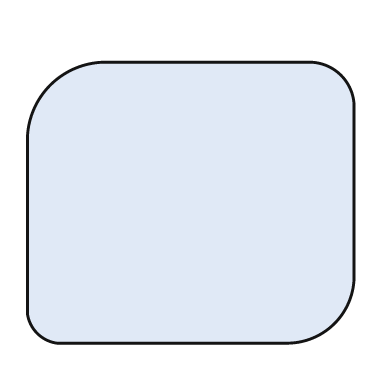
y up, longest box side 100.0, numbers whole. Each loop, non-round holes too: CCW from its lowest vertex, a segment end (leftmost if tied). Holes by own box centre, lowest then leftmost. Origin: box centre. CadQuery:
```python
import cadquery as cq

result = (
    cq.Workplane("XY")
    .moveTo(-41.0, -43.0)
    .lineTo(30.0, -43.0)
    .threePointArc((44.0, -37.0), (50.0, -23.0))
    .lineTo(50.0, 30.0)
    .threePointArc((46.0, 39.0), (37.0, 43.0))
    .lineTo(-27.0, 43.0)
    .threePointArc((-43.0, 36.0), (-50.0, 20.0))
    .lineTo(-50.0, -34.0)
    .threePointArc((-47.0, -40.0), (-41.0, -43.0))
    .close()
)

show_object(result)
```